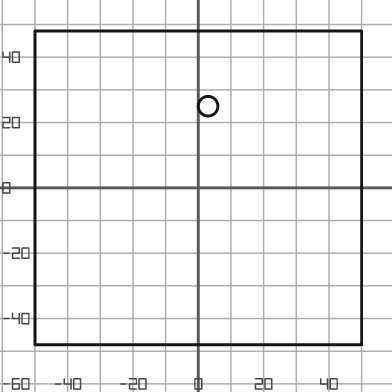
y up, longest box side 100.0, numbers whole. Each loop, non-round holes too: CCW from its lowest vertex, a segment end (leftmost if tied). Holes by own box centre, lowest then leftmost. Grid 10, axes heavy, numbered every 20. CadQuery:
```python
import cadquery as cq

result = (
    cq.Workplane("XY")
    .moveTo(-50.0, -48.0)
    .lineTo(50.0, -48.0)
    .lineTo(50.0, 48.0)
    .lineTo(-50.0, 48.0)
    .close()
    .moveTo(3.0, 25.0)
    .circle(3.0)
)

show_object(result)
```